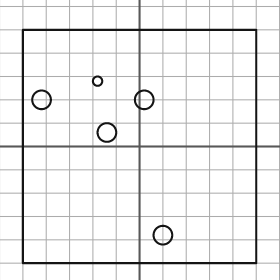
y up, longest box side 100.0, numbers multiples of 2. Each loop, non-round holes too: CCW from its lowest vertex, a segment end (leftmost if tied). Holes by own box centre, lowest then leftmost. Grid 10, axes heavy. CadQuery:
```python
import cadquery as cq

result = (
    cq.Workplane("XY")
    .moveTo(-50.0, -50.0)
    .lineTo(50.0, -50.0)
    .lineTo(50.0, 50.0)
    .lineTo(-50.0, 50.0)
    .close()
    .moveTo(10.0, -38.0)
    .circle(4.0)
    .moveTo(-14.0, 6.0)
    .circle(4.0)
    .moveTo(-42.0, 20.0)
    .circle(4.0)
    .moveTo(2.0, 20.0)
    .circle(4.0)
    .moveTo(-18.0, 28.0)
    .circle(2.0)
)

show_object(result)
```